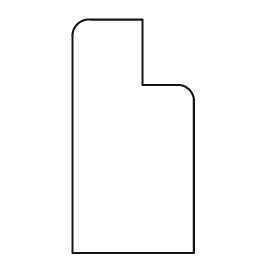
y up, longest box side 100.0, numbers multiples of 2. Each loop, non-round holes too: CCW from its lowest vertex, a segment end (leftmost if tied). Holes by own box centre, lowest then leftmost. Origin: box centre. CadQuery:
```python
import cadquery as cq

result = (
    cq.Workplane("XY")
    .moveTo(-26.0, -50.0)
    .lineTo(26.0, -50.0)
    .lineTo(26.0, 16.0)
    .threePointArc((24.0, 20.0), (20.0, 22.0))
    .lineTo(4.0, 22.0)
    .lineTo(4.0, 50.0)
    .lineTo(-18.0, 50.0)
    .threePointArc((-24.0, 48.0), (-26.0, 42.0))
    .close()
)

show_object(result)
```